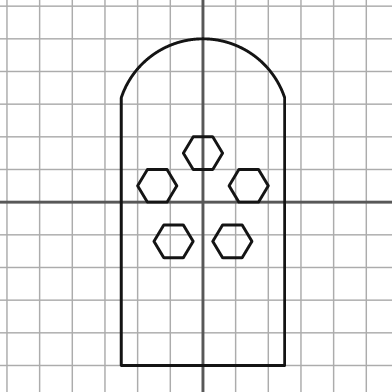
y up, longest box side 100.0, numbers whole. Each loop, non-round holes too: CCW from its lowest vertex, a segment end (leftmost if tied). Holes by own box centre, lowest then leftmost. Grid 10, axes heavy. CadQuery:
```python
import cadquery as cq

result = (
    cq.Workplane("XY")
    .moveTo(-25.0, -50.0)
    .lineTo(25.0, -50.0)
    .lineTo(25.0, 32.0)
    .threePointArc((0.0, 50.0), (-25.0, 32.0))
    .close()
    .moveTo(-12.0, -17.0)
    .lineTo(-6.0, -17.0)
    .lineTo(-3.0, -12.0)
    .lineTo(-6.0, -7.0)
    .lineTo(-12.0, -7.0)
    .lineTo(-15.0, -12.0)
    .close()
    .moveTo(6.0, -17.0)
    .lineTo(12.0, -17.0)
    .lineTo(15.0, -12.0)
    .lineTo(12.0, -7.0)
    .lineTo(6.0, -7.0)
    .lineTo(3.0, -12.0)
    .close()
    .moveTo(-17.0, 0.0)
    .lineTo(-11.0, 0.0)
    .lineTo(-8.0, 5.0)
    .lineTo(-11.0, 10.0)
    .lineTo(-17.0, 10.0)
    .lineTo(-20.0, 5.0)
    .close()
    .moveTo(11.0, 0.0)
    .lineTo(17.0, 0.0)
    .lineTo(20.0, 5.0)
    .lineTo(17.0, 10.0)
    .lineTo(11.0, 10.0)
    .lineTo(8.0, 5.0)
    .close()
    .moveTo(-3.0, 10.0)
    .lineTo(3.0, 10.0)
    .lineTo(6.0, 15.0)
    .lineTo(3.0, 20.0)
    .lineTo(-3.0, 20.0)
    .lineTo(-6.0, 15.0)
    .close()
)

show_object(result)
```